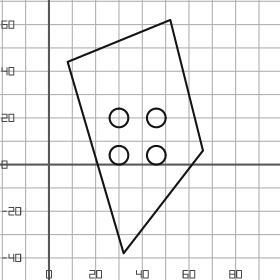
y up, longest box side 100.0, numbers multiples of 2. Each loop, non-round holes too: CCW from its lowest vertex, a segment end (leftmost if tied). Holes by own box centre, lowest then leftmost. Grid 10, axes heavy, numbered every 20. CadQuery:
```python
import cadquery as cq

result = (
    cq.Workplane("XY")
    .moveTo(32.0, -38.0)
    .lineTo(66.0, 6.0)
    .lineTo(52.0, 62.0)
    .lineTo(8.0, 44.0)
    .close()
    .moveTo(30.0, 4.0)
    .circle(4.0)
    .moveTo(46.0, 4.0)
    .circle(4.0)
    .moveTo(30.0, 20.0)
    .circle(4.0)
    .moveTo(46.0, 20.0)
    .circle(4.0)
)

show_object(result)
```